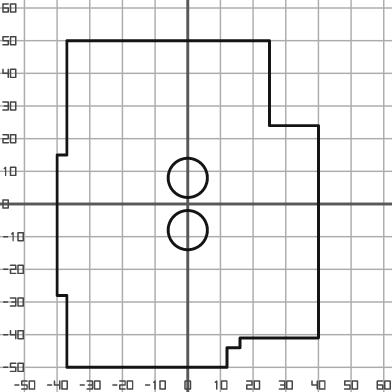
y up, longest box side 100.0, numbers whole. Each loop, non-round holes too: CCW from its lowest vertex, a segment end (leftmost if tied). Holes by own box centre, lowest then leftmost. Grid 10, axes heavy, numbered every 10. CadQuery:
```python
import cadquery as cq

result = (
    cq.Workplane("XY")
    .moveTo(-37.0, -50.0)
    .lineTo(12.0, -50.0)
    .lineTo(12.0, -44.0)
    .lineTo(16.0, -44.0)
    .lineTo(16.0, -41.0)
    .lineTo(40.0, -41.0)
    .lineTo(40.0, 24.0)
    .lineTo(25.0, 24.0)
    .lineTo(25.0, 50.0)
    .lineTo(-37.0, 50.0)
    .lineTo(-37.0, 15.0)
    .lineTo(-40.0, 15.0)
    .lineTo(-40.0, -28.0)
    .lineTo(-37.0, -28.0)
    .close()
    .moveTo(0.0, -8.0)
    .circle(6.0)
    .moveTo(0.0, 8.0)
    .circle(6.0)
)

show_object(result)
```